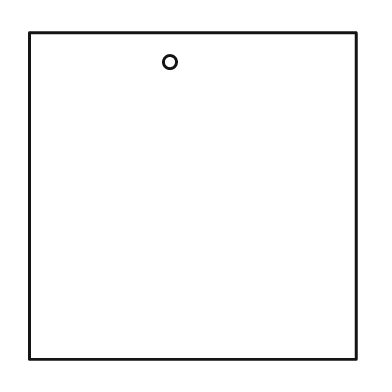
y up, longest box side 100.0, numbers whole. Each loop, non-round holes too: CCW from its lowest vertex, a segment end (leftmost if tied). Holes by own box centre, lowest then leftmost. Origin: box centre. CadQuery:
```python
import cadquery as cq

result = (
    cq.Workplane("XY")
    .moveTo(-50.0, -50.0)
    .lineTo(50.0, -50.0)
    .lineTo(50.0, 50.0)
    .lineTo(-50.0, 50.0)
    .close()
    .moveTo(-7.0, 41.0)
    .circle(2.0)
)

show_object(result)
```